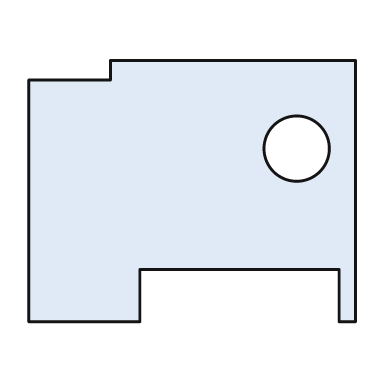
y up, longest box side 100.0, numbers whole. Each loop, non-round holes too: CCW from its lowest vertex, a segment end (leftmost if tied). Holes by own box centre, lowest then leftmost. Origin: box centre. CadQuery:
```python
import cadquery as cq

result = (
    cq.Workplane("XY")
    .moveTo(-50.0, -40.0)
    .lineTo(-16.0, -40.0)
    .lineTo(-16.0, -24.0)
    .lineTo(45.0, -24.0)
    .lineTo(45.0, -40.0)
    .lineTo(50.0, -40.0)
    .lineTo(50.0, 40.0)
    .lineTo(-25.0, 40.0)
    .lineTo(-25.0, 34.0)
    .lineTo(-50.0, 34.0)
    .close()
    .moveTo(32.0, 13.0)
    .circle(10.0)
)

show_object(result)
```